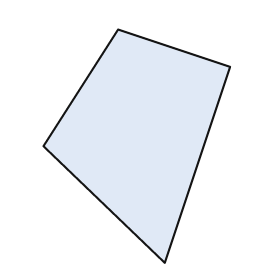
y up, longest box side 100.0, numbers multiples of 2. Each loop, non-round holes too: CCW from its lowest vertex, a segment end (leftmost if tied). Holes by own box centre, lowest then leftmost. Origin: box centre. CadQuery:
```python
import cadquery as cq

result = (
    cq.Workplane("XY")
    .moveTo(12.0, -50.0)
    .lineTo(40.0, 34.0)
    .lineTo(-8.0, 50.0)
    .lineTo(-40.0, 0.0)
    .close()
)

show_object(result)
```